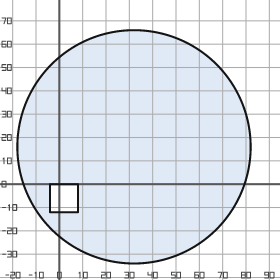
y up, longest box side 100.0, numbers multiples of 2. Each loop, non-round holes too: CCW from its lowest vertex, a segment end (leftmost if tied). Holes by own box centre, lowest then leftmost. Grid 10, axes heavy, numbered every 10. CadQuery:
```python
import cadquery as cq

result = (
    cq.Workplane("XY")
    .moveTo(32.0, 16.0)
    .circle(50.0)
    .moveTo(-4.0, -12.0)
    .lineTo(8.0, -12.0)
    .lineTo(8.0, 0.0)
    .lineTo(-4.0, 0.0)
    .close()
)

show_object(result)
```